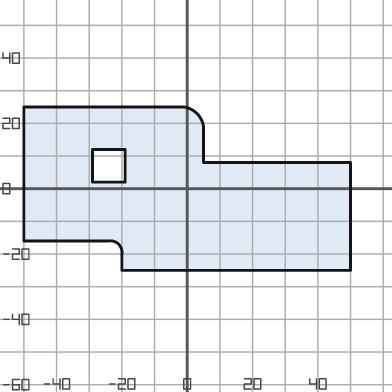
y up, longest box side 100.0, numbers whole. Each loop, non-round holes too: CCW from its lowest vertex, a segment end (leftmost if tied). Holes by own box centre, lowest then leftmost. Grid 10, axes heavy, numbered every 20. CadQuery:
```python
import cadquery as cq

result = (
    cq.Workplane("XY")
    .moveTo(-20.0, -25.0)
    .lineTo(50.0, -25.0)
    .lineTo(50.0, 8.0)
    .lineTo(5.0, 8.0)
    .lineTo(5.0, 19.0)
    .threePointArc((3.0, 23.0), (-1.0, 25.0))
    .lineTo(-50.0, 25.0)
    .lineTo(-50.0, -16.0)
    .lineTo(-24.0, -16.0)
    .threePointArc((-21.0, -17.0), (-20.0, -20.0))
    .close()
    .moveTo(-29.0, 2.0)
    .lineTo(-19.0, 2.0)
    .lineTo(-19.0, 12.0)
    .lineTo(-29.0, 12.0)
    .close()
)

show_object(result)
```